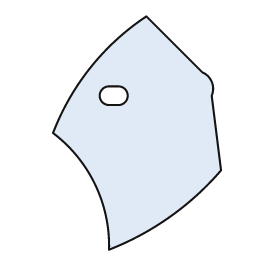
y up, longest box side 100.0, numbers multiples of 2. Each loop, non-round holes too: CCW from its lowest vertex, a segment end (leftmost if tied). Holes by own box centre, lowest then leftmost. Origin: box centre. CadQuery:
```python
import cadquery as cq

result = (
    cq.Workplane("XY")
    .moveTo(-12.0, -50.0)
    .threePointArc((14.0, -36.0), (36.0, -16.0))
    .lineTo(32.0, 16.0)
    .threePointArc((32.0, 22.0), (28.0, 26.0))
    .lineTo(4.0, 50.0)
    .threePointArc((-20.0, 28.0), (-36.0, 0.0))
    .threePointArc((-18.0, -22.0), (-12.0, -50.0))
    .close()
    .moveTo(-12.0, 12.0)
    .lineTo(-8.0, 12.0)
    .threePointArc((-4.0, 16.0), (-8.0, 20.0))
    .lineTo(-12.0, 20.0)
    .threePointArc((-16.0, 16.0), (-12.0, 12.0))
    .close()
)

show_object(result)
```